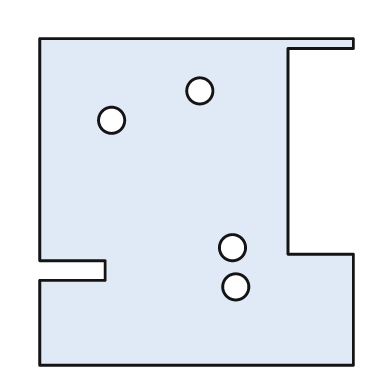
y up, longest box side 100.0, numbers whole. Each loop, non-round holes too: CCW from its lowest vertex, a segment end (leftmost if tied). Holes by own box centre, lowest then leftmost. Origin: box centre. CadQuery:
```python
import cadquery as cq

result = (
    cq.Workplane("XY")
    .moveTo(-48.0, -50.0)
    .lineTo(48.0, -50.0)
    .lineTo(48.0, -16.0)
    .lineTo(28.0, -16.0)
    .lineTo(28.0, 47.0)
    .lineTo(48.0, 47.0)
    .lineTo(48.0, 50.0)
    .lineTo(-48.0, 50.0)
    .lineTo(-48.0, -18.0)
    .lineTo(-28.0, -18.0)
    .lineTo(-28.0, -24.0)
    .lineTo(-48.0, -24.0)
    .close()
    .moveTo(12.0, -26.0)
    .circle(4.0)
    .moveTo(11.0, -14.0)
    .circle(4.0)
    .moveTo(-26.0, 25.0)
    .circle(4.0)
    .moveTo(1.0, 34.0)
    .circle(4.0)
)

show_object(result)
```